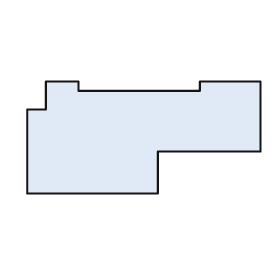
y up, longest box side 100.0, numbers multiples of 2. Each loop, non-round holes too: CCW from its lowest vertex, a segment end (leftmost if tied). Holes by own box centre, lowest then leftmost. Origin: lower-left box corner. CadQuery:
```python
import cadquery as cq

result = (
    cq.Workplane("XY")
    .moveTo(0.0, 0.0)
    .lineTo(56.0, 0.0)
    .lineTo(56.0, 18.0)
    .lineTo(100.0, 18.0)
    .lineTo(100.0, 48.0)
    .lineTo(74.0, 48.0)
    .lineTo(74.0, 44.0)
    .lineTo(22.0, 44.0)
    .lineTo(22.0, 48.0)
    .lineTo(8.0, 48.0)
    .lineTo(8.0, 36.0)
    .lineTo(0.0, 36.0)
    .close()
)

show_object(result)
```